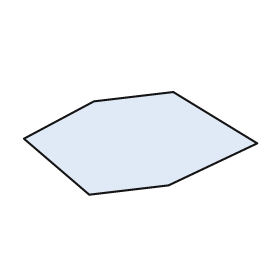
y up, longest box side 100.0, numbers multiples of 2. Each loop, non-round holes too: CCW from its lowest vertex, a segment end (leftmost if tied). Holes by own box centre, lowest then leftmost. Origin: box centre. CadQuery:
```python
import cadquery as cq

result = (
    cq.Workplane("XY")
    .moveTo(-22.0, -22.0)
    .lineTo(12.0, -18.0)
    .lineTo(50.0, 0.0)
    .lineTo(14.0, 22.0)
    .lineTo(-20.0, 18.0)
    .lineTo(-50.0, 2.0)
    .close()
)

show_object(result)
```